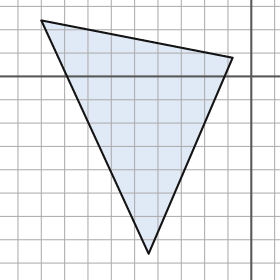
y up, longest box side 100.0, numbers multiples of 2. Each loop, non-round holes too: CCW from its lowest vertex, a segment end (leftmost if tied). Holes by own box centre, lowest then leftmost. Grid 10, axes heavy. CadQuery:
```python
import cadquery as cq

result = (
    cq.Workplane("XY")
    .moveTo(-44.0, -76.0)
    .lineTo(-8.0, 8.0)
    .lineTo(-90.0, 24.0)
    .close()
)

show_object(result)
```